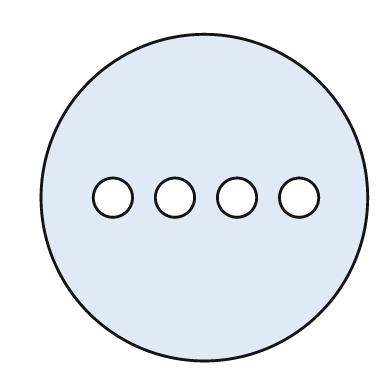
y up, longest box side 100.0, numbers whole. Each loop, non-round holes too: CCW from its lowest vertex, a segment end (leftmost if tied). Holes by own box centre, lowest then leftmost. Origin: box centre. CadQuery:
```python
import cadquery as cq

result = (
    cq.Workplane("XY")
    .moveTo(0.0, 0.0)
    .circle(50.0)
    .moveTo(-28.0, 0.0)
    .circle(6.0)
    .moveTo(-9.0, 0.0)
    .circle(6.0)
    .moveTo(10.0, 0.0)
    .circle(6.0)
    .moveTo(29.0, 0.0)
    .circle(6.0)
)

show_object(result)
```